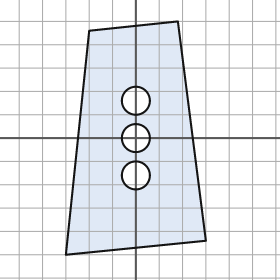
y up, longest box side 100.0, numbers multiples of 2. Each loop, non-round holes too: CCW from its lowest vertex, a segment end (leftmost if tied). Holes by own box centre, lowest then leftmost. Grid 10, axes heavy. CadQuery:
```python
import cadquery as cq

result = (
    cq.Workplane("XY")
    .moveTo(-30.0, -50.0)
    .lineTo(30.0, -44.0)
    .lineTo(18.0, 50.0)
    .lineTo(-20.0, 46.0)
    .close()
    .moveTo(0.0, -16.0)
    .circle(6.0)
    .moveTo(0.0, 0.0)
    .circle(6.0)
    .moveTo(0.0, 16.0)
    .circle(6.0)
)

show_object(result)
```